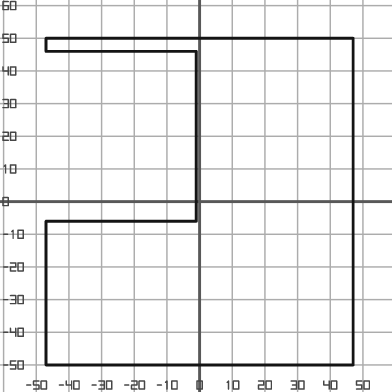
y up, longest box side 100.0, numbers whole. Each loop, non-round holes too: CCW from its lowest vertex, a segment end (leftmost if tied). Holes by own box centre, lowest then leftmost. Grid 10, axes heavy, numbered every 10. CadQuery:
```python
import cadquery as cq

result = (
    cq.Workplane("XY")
    .moveTo(-47.0, -50.0)
    .lineTo(47.0, -50.0)
    .lineTo(47.0, 50.0)
    .lineTo(-47.0, 50.0)
    .lineTo(-47.0, 46.0)
    .lineTo(-1.0, 46.0)
    .lineTo(-1.0, -6.0)
    .lineTo(-47.0, -6.0)
    .close()
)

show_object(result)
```